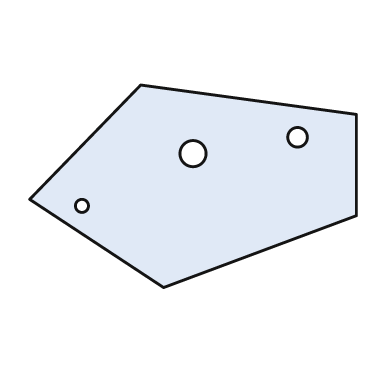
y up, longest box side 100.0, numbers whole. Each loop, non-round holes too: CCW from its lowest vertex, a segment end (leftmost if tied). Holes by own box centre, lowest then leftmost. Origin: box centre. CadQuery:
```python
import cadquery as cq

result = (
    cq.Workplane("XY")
    .moveTo(-9.0, -31.0)
    .lineTo(50.0, -9.0)
    .lineTo(50.0, 22.0)
    .lineTo(-16.0, 31.0)
    .lineTo(-50.0, -4.0)
    .close()
    .moveTo(-34.0, -6.0)
    .circle(2.0)
    .moveTo(0.0, 10.0)
    .circle(4.0)
    .moveTo(32.0, 15.0)
    .circle(3.0)
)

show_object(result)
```